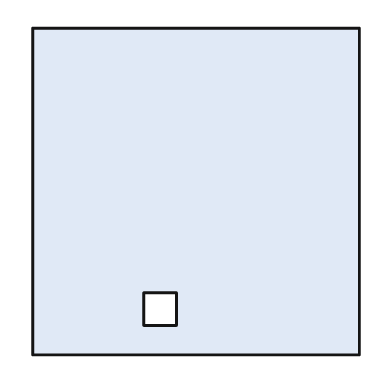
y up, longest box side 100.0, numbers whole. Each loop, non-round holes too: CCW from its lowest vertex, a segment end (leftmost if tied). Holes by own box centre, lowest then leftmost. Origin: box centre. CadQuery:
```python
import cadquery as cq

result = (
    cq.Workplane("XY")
    .moveTo(-50.0, -50.0)
    .lineTo(50.0, -50.0)
    .lineTo(50.0, 50.0)
    .lineTo(-50.0, 50.0)
    .close()
    .moveTo(-16.0, -41.0)
    .lineTo(-6.0, -41.0)
    .lineTo(-6.0, -31.0)
    .lineTo(-16.0, -31.0)
    .close()
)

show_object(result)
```